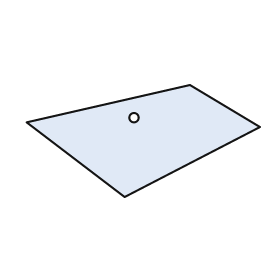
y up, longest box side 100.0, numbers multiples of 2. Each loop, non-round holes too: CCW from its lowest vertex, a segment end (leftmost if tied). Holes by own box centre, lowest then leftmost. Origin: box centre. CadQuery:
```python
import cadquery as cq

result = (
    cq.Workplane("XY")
    .moveTo(-8.0, -24.0)
    .lineTo(50.0, 6.0)
    .lineTo(20.0, 24.0)
    .lineTo(-50.0, 8.0)
    .close()
    .moveTo(-4.0, 10.0)
    .circle(2.0)
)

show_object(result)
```